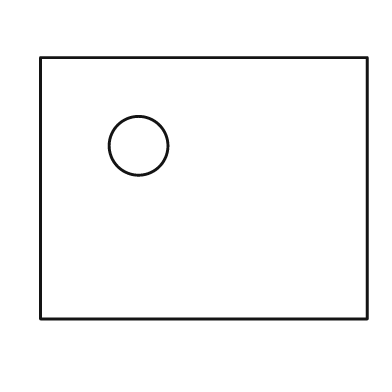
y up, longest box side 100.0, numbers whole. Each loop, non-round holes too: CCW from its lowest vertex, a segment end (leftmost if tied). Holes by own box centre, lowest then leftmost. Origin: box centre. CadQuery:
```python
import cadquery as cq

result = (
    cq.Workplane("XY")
    .moveTo(-50.0, -40.0)
    .lineTo(50.0, -40.0)
    .lineTo(50.0, 40.0)
    .lineTo(-50.0, 40.0)
    .close()
    .moveTo(-20.0, 13.0)
    .circle(9.0)
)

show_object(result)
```